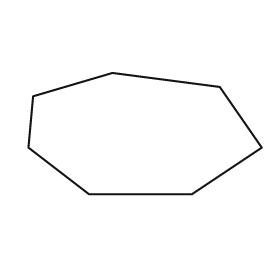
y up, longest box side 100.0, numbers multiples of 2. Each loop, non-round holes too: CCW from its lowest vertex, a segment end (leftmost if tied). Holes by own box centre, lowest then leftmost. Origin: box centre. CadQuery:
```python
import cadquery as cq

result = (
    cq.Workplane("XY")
    .moveTo(-24.0, -26.0)
    .lineTo(20.0, -26.0)
    .lineTo(50.0, -6.0)
    .lineTo(32.0, 20.0)
    .lineTo(-14.0, 26.0)
    .lineTo(-48.0, 16.0)
    .lineTo(-50.0, -6.0)
    .close()
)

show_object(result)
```